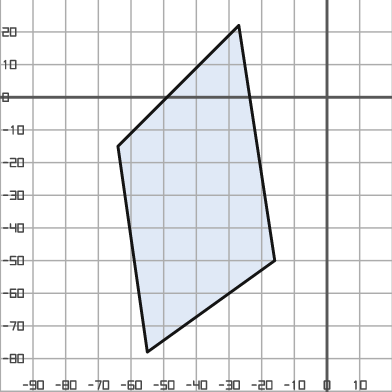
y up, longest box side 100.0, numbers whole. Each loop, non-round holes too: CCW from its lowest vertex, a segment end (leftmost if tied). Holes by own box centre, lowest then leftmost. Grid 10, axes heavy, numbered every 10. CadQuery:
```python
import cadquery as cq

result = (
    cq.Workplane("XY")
    .moveTo(-55.0, -78.0)
    .lineTo(-16.0, -50.0)
    .lineTo(-27.0, 22.0)
    .lineTo(-64.0, -15.0)
    .close()
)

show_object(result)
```